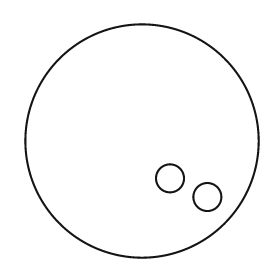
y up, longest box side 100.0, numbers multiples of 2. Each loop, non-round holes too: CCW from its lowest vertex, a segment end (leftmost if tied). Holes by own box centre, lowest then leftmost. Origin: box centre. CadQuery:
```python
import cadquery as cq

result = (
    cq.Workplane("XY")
    .moveTo(0.0, 0.0)
    .circle(50.0)
    .moveTo(28.0, -24.0)
    .circle(6.0)
    .moveTo(12.0, -16.0)
    .circle(6.0)
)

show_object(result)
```